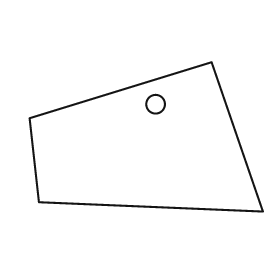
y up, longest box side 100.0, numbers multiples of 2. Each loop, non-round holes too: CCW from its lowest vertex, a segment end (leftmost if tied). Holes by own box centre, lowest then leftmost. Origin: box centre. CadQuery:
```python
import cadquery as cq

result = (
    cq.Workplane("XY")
    .moveTo(50.0, -32.0)
    .lineTo(28.0, 32.0)
    .lineTo(-50.0, 8.0)
    .lineTo(-46.0, -28.0)
    .close()
    .moveTo(4.0, 14.0)
    .circle(4.0)
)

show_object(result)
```